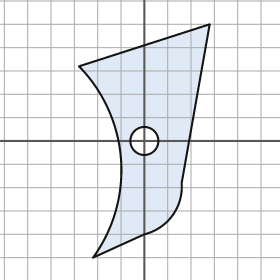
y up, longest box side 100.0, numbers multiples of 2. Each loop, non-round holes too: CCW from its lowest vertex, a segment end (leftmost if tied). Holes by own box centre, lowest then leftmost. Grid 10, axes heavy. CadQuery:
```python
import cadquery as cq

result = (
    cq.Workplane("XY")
    .moveTo(-22.0, -50.0)
    .lineTo(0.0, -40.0)
    .threePointArc((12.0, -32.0), (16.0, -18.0))
    .lineTo(28.0, 50.0)
    .lineTo(-28.0, 32.0)
    .threePointArc((-10.0, -8.0), (-22.0, -50.0))
    .close()
    .moveTo(0.0, 0.0)
    .circle(6.0)
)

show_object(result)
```